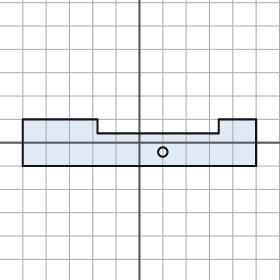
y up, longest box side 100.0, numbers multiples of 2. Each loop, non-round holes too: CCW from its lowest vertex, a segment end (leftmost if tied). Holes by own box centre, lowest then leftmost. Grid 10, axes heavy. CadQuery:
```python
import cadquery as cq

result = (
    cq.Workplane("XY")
    .moveTo(-50.0, -10.0)
    .lineTo(50.0, -10.0)
    .lineTo(50.0, 10.0)
    .lineTo(34.0, 10.0)
    .lineTo(34.0, 4.0)
    .lineTo(-18.0, 4.0)
    .lineTo(-18.0, 10.0)
    .lineTo(-50.0, 10.0)
    .close()
    .moveTo(10.0, -4.0)
    .circle(2.0)
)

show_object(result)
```